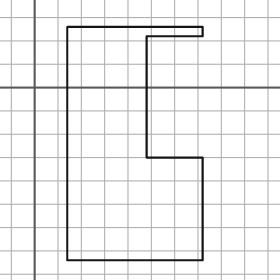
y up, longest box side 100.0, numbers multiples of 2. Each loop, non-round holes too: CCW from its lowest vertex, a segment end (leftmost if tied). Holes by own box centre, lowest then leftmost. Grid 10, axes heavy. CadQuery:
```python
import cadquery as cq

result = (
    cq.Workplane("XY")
    .moveTo(14.0, -74.0)
    .lineTo(72.0, -74.0)
    .lineTo(72.0, -30.0)
    .lineTo(48.0, -30.0)
    .lineTo(48.0, 22.0)
    .lineTo(72.0, 22.0)
    .lineTo(72.0, 26.0)
    .lineTo(14.0, 26.0)
    .close()
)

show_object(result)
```